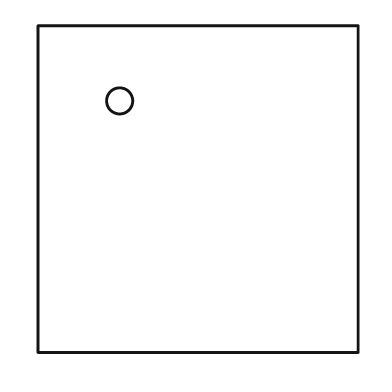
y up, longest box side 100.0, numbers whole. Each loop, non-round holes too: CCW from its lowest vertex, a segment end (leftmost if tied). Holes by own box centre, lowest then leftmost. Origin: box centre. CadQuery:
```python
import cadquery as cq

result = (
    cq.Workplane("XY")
    .moveTo(-49.0, -50.0)
    .lineTo(49.0, -50.0)
    .lineTo(49.0, 50.0)
    .lineTo(-49.0, 50.0)
    .close()
    .moveTo(-24.0, 27.0)
    .circle(4.0)
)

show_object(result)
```